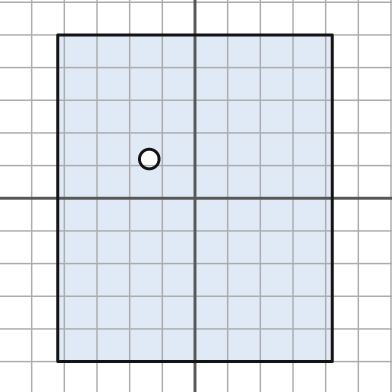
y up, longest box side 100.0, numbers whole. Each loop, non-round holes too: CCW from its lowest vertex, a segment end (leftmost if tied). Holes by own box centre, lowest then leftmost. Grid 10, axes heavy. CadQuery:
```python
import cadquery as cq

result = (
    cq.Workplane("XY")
    .moveTo(-42.0, -50.0)
    .lineTo(42.0, -50.0)
    .lineTo(42.0, 50.0)
    .lineTo(-42.0, 50.0)
    .close()
    .moveTo(-14.0, 12.0)
    .circle(3.0)
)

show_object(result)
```